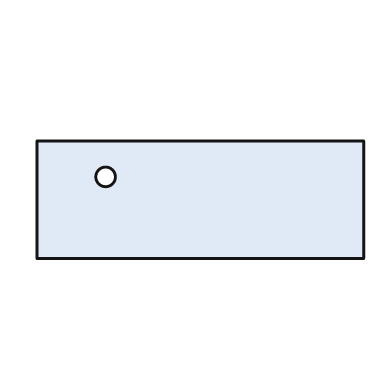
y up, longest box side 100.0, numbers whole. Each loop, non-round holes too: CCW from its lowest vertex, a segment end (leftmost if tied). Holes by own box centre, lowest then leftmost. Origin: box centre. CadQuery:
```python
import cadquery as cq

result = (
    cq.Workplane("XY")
    .moveTo(-50.0, -18.0)
    .lineTo(50.0, -18.0)
    .lineTo(50.0, 18.0)
    .lineTo(-50.0, 18.0)
    .close()
    .moveTo(-29.0, 7.0)
    .circle(3.0)
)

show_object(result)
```